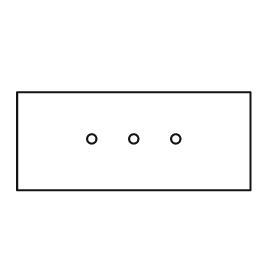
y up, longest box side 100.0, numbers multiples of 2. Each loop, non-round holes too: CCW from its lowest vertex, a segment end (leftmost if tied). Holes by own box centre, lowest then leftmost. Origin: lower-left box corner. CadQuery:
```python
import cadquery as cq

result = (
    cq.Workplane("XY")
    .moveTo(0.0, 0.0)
    .lineTo(100.0, 0.0)
    .lineTo(100.0, 42.0)
    .lineTo(0.0, 42.0)
    .close()
    .moveTo(32.0, 22.0)
    .circle(2.0)
    .moveTo(50.0, 22.0)
    .circle(2.0)
    .moveTo(68.0, 22.0)
    .circle(2.0)
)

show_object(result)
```